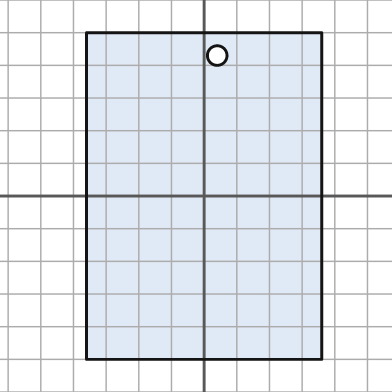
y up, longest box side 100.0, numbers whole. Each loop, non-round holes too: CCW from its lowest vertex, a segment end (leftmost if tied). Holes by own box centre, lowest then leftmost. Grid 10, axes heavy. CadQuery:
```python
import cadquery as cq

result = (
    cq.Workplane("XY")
    .moveTo(-36.0, -50.0)
    .lineTo(36.0, -50.0)
    .lineTo(36.0, 50.0)
    .lineTo(-36.0, 50.0)
    .close()
    .moveTo(4.0, 43.0)
    .circle(3.0)
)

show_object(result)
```